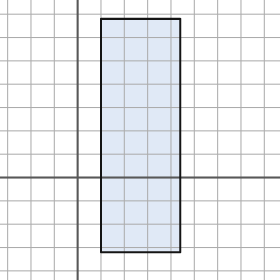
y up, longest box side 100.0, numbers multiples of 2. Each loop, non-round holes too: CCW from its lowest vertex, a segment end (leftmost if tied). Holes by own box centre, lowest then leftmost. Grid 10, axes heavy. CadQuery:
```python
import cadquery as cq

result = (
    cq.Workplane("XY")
    .moveTo(10.0, -32.0)
    .lineTo(44.0, -32.0)
    .lineTo(44.0, 68.0)
    .lineTo(10.0, 68.0)
    .close()
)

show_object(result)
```